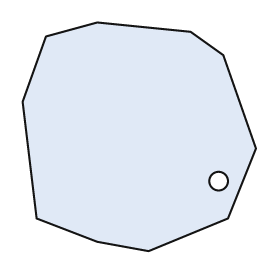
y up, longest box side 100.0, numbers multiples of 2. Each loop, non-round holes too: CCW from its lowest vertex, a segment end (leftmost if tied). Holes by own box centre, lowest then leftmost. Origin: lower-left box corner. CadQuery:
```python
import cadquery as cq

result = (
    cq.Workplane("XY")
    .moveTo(54.0, 0.0)
    .lineTo(88.0, 14.0)
    .lineTo(100.0, 44.0)
    .lineTo(86.0, 84.0)
    .lineTo(72.0, 94.0)
    .lineTo(32.0, 98.0)
    .lineTo(10.0, 92.0)
    .lineTo(0.0, 64.0)
    .lineTo(6.0, 14.0)
    .lineTo(32.0, 4.0)
    .close()
    .moveTo(84.0, 30.0)
    .circle(4.0)
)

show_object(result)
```